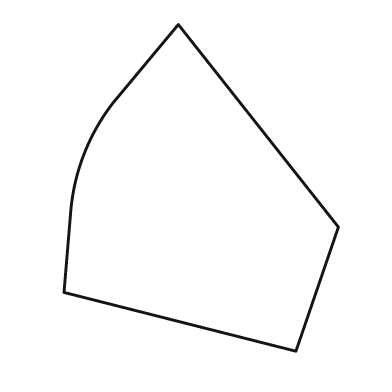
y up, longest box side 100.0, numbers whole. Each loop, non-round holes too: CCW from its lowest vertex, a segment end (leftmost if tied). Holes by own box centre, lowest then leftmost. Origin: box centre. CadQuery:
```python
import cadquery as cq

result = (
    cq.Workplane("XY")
    .moveTo(29.0, -50.0)
    .lineTo(42.0, -12.0)
    .lineTo(-7.0, 50.0)
    .lineTo(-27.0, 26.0)
    .threePointArc((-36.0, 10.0), (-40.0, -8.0))
    .lineTo(-42.0, -32.0)
    .close()
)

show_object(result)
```